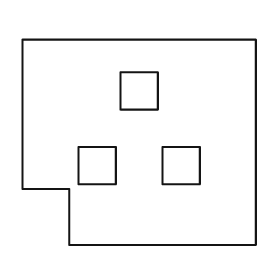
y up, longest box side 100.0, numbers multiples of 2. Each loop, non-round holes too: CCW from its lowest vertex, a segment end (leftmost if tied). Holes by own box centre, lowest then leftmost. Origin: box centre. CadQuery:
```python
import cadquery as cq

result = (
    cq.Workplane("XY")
    .moveTo(-30.0, -44.0)
    .lineTo(50.0, -44.0)
    .lineTo(50.0, 44.0)
    .lineTo(-50.0, 44.0)
    .lineTo(-50.0, -20.0)
    .lineTo(-30.0, -20.0)
    .close()
    .moveTo(-26.0, -18.0)
    .lineTo(-10.0, -18.0)
    .lineTo(-10.0, -2.0)
    .lineTo(-26.0, -2.0)
    .close()
    .moveTo(10.0, -18.0)
    .lineTo(26.0, -18.0)
    .lineTo(26.0, -2.0)
    .lineTo(10.0, -2.0)
    .close()
    .moveTo(-8.0, 14.0)
    .lineTo(8.0, 14.0)
    .lineTo(8.0, 30.0)
    .lineTo(-8.0, 30.0)
    .close()
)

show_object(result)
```